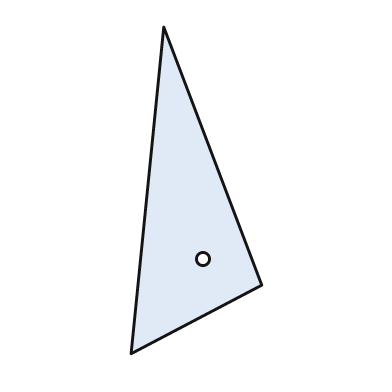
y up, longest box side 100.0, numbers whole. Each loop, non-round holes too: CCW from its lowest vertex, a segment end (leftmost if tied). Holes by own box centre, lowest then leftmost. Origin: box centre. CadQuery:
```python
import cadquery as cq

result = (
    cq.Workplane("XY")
    .moveTo(-20.0, -50.0)
    .lineTo(20.0, -29.0)
    .lineTo(-10.0, 50.0)
    .close()
    .moveTo(2.0, -21.0)
    .circle(2.0)
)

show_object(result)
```